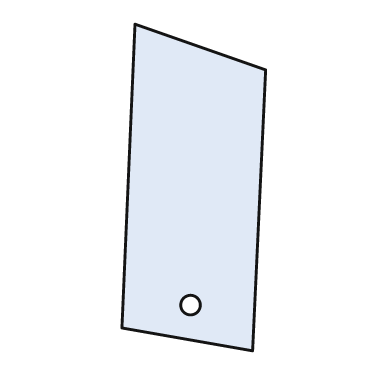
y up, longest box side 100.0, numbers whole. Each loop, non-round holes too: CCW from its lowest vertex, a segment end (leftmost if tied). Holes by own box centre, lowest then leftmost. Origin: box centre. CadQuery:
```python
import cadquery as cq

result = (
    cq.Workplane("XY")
    .moveTo(18.0, -50.0)
    .lineTo(22.0, 36.0)
    .lineTo(-18.0, 50.0)
    .lineTo(-22.0, -43.0)
    .close()
    .moveTo(-1.0, -36.0)
    .circle(3.0)
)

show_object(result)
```